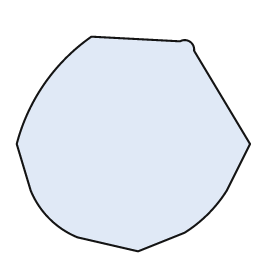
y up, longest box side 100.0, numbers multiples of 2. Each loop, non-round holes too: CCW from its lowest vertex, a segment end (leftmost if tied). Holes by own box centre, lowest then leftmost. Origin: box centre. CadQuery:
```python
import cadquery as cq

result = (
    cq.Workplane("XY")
    .moveTo(2.0, -46.0)
    .lineTo(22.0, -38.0)
    .threePointArc((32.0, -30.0), (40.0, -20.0))
    .lineTo(50.0, 0.0)
    .lineTo(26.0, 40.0)
    .threePointArc((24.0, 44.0), (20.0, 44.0))
    .lineTo(-18.0, 46.0)
    .threePointArc((-38.0, 26.0), (-50.0, 0.0))
    .lineTo(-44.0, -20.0)
    .threePointArc((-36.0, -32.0), (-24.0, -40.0))
    .close()
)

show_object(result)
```